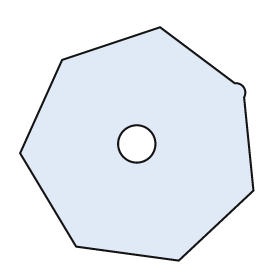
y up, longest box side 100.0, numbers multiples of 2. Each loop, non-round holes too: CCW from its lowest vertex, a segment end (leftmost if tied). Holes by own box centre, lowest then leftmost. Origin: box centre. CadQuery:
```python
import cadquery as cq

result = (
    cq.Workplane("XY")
    .moveTo(18.0, -50.0)
    .lineTo(50.0, -20.0)
    .lineTo(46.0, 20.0)
    .threePointArc((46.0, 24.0), (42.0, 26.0))
    .lineTo(10.0, 50.0)
    .lineTo(-32.0, 36.0)
    .lineTo(-50.0, -4.0)
    .lineTo(-26.0, -44.0)
    .close()
    .moveTo(0.0, 0.0)
    .circle(8.0)
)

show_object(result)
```